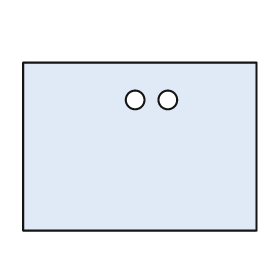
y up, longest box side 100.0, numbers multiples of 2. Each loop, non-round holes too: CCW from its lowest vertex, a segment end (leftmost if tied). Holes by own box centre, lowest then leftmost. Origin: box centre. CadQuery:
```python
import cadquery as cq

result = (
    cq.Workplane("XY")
    .moveTo(-50.0, -36.0)
    .lineTo(50.0, -36.0)
    .lineTo(50.0, 36.0)
    .lineTo(-50.0, 36.0)
    .close()
    .moveTo(-2.0, 20.0)
    .circle(4.0)
    .moveTo(12.0, 20.0)
    .circle(4.0)
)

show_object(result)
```